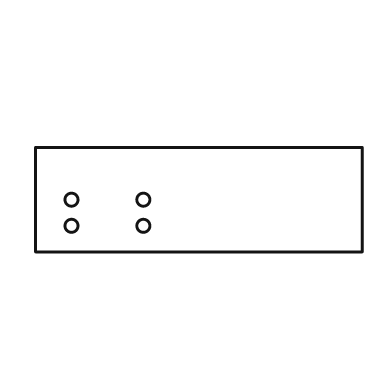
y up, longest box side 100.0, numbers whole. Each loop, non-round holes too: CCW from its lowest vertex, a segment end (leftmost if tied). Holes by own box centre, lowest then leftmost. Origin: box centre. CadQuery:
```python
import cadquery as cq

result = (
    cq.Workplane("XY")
    .moveTo(-50.0, -16.0)
    .lineTo(50.0, -16.0)
    .lineTo(50.0, 16.0)
    .lineTo(-50.0, 16.0)
    .close()
    .moveTo(-39.0, -8.0)
    .circle(2.0)
    .moveTo(-17.0, -8.0)
    .circle(2.0)
    .moveTo(-39.0, 0.0)
    .circle(2.0)
    .moveTo(-17.0, 0.0)
    .circle(2.0)
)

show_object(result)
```